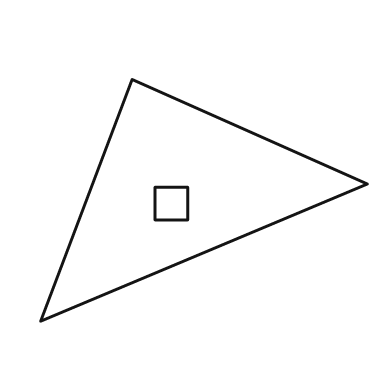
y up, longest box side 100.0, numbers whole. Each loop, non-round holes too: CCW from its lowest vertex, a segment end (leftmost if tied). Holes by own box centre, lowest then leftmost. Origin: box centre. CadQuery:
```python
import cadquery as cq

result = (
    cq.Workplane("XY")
    .moveTo(-50.0, -37.0)
    .lineTo(50.0, 5.0)
    .lineTo(-22.0, 37.0)
    .close()
    .moveTo(-15.0, -6.0)
    .lineTo(-5.0, -6.0)
    .lineTo(-5.0, 4.0)
    .lineTo(-15.0, 4.0)
    .close()
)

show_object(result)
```